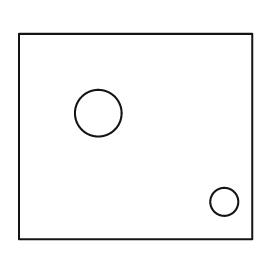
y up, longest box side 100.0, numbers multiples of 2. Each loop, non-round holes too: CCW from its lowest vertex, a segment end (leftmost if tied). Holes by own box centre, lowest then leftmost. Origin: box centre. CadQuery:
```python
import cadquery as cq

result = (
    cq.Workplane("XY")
    .moveTo(-50.0, -44.0)
    .lineTo(50.0, -44.0)
    .lineTo(50.0, 44.0)
    .lineTo(-50.0, 44.0)
    .close()
    .moveTo(38.0, -28.0)
    .circle(6.0)
    .moveTo(-16.0, 10.0)
    .circle(10.0)
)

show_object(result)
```